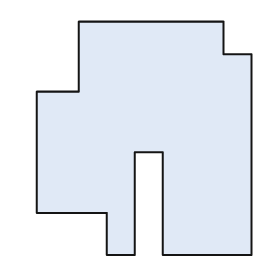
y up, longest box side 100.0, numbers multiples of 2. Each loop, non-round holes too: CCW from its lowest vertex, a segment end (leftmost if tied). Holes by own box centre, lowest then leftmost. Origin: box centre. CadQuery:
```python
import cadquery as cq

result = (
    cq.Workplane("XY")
    .moveTo(-16.0, -50.0)
    .lineTo(-4.0, -50.0)
    .lineTo(-4.0, -6.0)
    .lineTo(8.0, -6.0)
    .lineTo(8.0, -50.0)
    .lineTo(46.0, -50.0)
    .lineTo(46.0, 36.0)
    .lineTo(34.0, 36.0)
    .lineTo(34.0, 50.0)
    .lineTo(-28.0, 50.0)
    .lineTo(-28.0, 20.0)
    .lineTo(-46.0, 20.0)
    .lineTo(-46.0, -32.0)
    .lineTo(-16.0, -32.0)
    .close()
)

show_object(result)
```